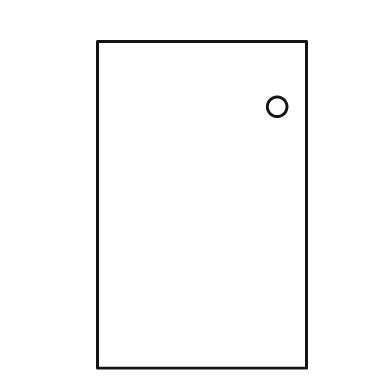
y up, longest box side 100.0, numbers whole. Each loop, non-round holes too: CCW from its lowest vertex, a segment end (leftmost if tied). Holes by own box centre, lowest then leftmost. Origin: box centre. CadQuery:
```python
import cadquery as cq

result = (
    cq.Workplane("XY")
    .moveTo(-32.0, -50.0)
    .lineTo(32.0, -50.0)
    .lineTo(32.0, 50.0)
    .lineTo(-32.0, 50.0)
    .close()
    .moveTo(23.0, 30.0)
    .circle(3.0)
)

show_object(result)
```